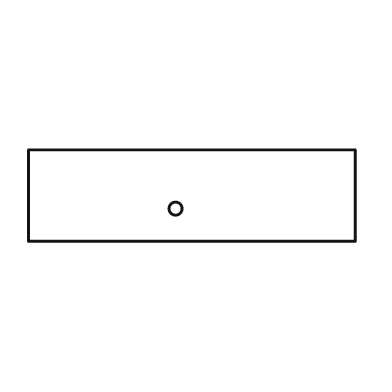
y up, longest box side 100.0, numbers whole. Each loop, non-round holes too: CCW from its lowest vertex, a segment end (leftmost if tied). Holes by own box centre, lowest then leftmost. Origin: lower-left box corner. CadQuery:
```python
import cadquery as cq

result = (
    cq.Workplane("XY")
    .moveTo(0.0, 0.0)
    .lineTo(100.0, 0.0)
    .lineTo(100.0, 28.0)
    .lineTo(0.0, 28.0)
    .close()
    .moveTo(45.0, 10.0)
    .circle(2.0)
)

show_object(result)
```